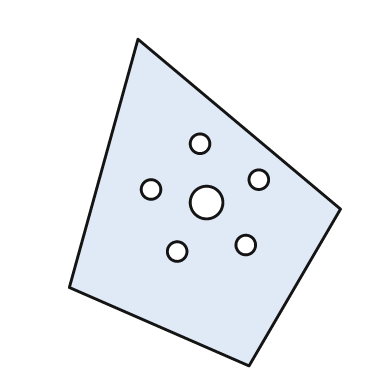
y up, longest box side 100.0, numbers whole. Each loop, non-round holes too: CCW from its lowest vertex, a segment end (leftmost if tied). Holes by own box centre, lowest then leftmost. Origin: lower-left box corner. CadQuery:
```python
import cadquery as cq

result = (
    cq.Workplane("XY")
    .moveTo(55.0, 0.0)
    .lineTo(83.0, 48.0)
    .lineTo(21.0, 100.0)
    .lineTo(0.0, 24.0)
    .close()
    .moveTo(33.0, 35.0)
    .circle(3.0)
    .moveTo(54.0, 37.0)
    .circle(3.0)
    .moveTo(42.0, 50.0)
    .circle(5.0)
    .moveTo(25.0, 54.0)
    .circle(3.0)
    .moveTo(58.0, 57.0)
    .circle(3.0)
    .moveTo(40.0, 68.0)
    .circle(3.0)
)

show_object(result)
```